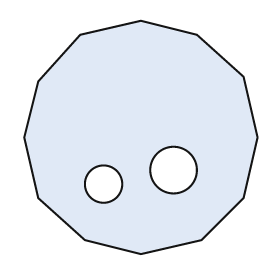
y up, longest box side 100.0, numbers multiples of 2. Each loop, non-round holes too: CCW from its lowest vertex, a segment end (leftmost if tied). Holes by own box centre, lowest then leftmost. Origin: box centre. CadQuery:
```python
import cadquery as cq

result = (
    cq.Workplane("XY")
    .moveTo(0.0, -50.0)
    .lineTo(26.0, -44.0)
    .lineTo(44.0, -26.0)
    .lineTo(50.0, 0.0)
    .lineTo(44.0, 26.0)
    .lineTo(24.0, 44.0)
    .lineTo(0.0, 50.0)
    .lineTo(-26.0, 44.0)
    .lineTo(-44.0, 24.0)
    .lineTo(-50.0, 0.0)
    .lineTo(-44.0, -26.0)
    .lineTo(-24.0, -44.0)
    .close()
    .moveTo(-16.0, -20.0)
    .circle(8.0)
    .moveTo(14.0, -14.0)
    .circle(10.0)
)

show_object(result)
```